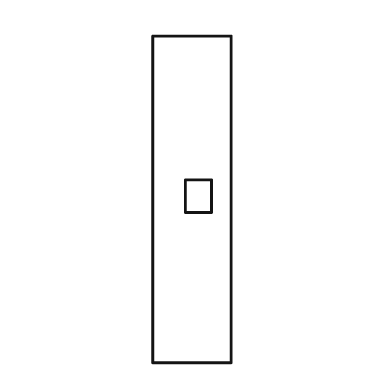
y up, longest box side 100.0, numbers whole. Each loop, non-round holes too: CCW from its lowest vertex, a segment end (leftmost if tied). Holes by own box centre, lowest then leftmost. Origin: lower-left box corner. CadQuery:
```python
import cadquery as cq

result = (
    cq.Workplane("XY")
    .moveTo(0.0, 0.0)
    .lineTo(24.0, 0.0)
    .lineTo(24.0, 100.0)
    .lineTo(0.0, 100.0)
    .close()
    .moveTo(10.0, 46.0)
    .lineTo(18.0, 46.0)
    .lineTo(18.0, 56.0)
    .lineTo(10.0, 56.0)
    .close()
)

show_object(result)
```